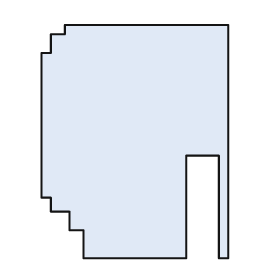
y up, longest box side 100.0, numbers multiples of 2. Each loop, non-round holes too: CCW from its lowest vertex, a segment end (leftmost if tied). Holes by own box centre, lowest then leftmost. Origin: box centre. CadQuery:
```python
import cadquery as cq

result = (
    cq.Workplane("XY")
    .moveTo(-22.0, -50.0)
    .lineTo(22.0, -50.0)
    .lineTo(22.0, -6.0)
    .lineTo(36.0, -6.0)
    .lineTo(36.0, -50.0)
    .lineTo(40.0, -50.0)
    .lineTo(40.0, 50.0)
    .lineTo(-30.0, 50.0)
    .lineTo(-30.0, 46.0)
    .lineTo(-36.0, 46.0)
    .lineTo(-36.0, 38.0)
    .lineTo(-40.0, 38.0)
    .lineTo(-40.0, -24.0)
    .lineTo(-36.0, -24.0)
    .lineTo(-36.0, -30.0)
    .lineTo(-28.0, -30.0)
    .lineTo(-28.0, -38.0)
    .lineTo(-22.0, -38.0)
    .close()
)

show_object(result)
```